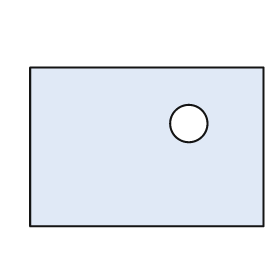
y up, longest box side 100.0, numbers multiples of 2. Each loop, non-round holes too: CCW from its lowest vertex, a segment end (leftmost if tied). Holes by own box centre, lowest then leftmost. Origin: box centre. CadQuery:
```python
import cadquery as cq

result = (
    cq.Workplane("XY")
    .moveTo(-50.0, -34.0)
    .lineTo(50.0, -34.0)
    .lineTo(50.0, 34.0)
    .lineTo(-50.0, 34.0)
    .close()
    .moveTo(18.0, 10.0)
    .circle(8.0)
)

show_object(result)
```